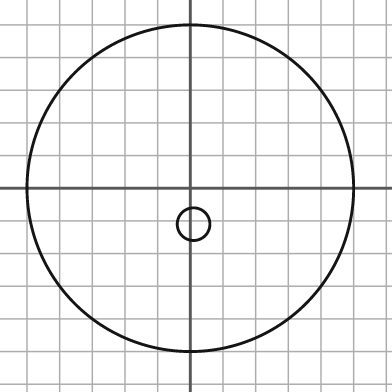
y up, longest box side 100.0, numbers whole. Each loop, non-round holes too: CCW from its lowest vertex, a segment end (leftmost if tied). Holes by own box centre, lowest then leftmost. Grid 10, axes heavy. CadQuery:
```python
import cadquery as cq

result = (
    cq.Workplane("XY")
    .moveTo(0.0, 0.0)
    .circle(50.0)
    .moveTo(1.0, -11.0)
    .circle(5.0)
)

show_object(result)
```